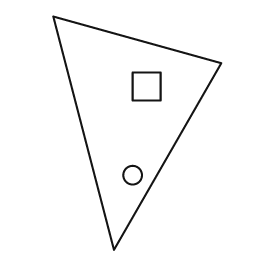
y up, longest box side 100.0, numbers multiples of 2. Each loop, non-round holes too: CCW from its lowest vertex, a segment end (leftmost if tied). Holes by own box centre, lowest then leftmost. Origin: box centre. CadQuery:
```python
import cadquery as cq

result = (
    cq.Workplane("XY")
    .moveTo(-10.0, -50.0)
    .lineTo(36.0, 30.0)
    .lineTo(-36.0, 50.0)
    .close()
    .moveTo(-2.0, -18.0)
    .circle(4.0)
    .moveTo(-2.0, 14.0)
    .lineTo(10.0, 14.0)
    .lineTo(10.0, 26.0)
    .lineTo(-2.0, 26.0)
    .close()
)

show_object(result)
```